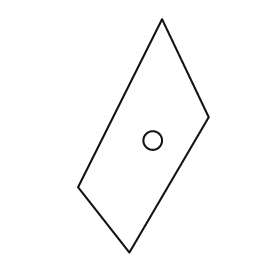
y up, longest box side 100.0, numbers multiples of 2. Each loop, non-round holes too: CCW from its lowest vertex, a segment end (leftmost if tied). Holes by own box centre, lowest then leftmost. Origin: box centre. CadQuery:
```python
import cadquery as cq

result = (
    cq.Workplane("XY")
    .moveTo(-6.0, -50.0)
    .lineTo(28.0, 8.0)
    .lineTo(8.0, 50.0)
    .lineTo(-28.0, -22.0)
    .close()
    .moveTo(4.0, -2.0)
    .circle(4.0)
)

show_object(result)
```